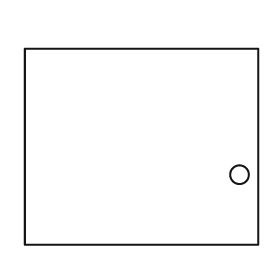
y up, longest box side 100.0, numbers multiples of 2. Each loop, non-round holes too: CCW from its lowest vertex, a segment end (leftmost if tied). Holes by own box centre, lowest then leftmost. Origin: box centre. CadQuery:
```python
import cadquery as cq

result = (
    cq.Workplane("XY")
    .moveTo(-50.0, -42.0)
    .lineTo(50.0, -42.0)
    .lineTo(50.0, 42.0)
    .lineTo(-50.0, 42.0)
    .close()
    .moveTo(42.0, -12.0)
    .circle(4.0)
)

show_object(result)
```